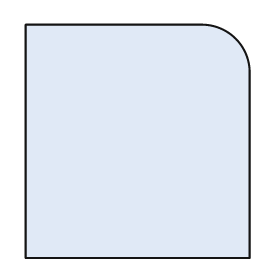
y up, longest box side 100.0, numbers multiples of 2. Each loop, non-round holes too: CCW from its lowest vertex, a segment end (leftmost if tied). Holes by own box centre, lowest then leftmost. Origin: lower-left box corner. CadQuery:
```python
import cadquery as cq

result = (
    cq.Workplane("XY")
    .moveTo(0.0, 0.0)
    .lineTo(96.0, 0.0)
    .lineTo(96.0, 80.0)
    .threePointArc((90.0, 94.0), (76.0, 100.0))
    .lineTo(0.0, 100.0)
    .close()
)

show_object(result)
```